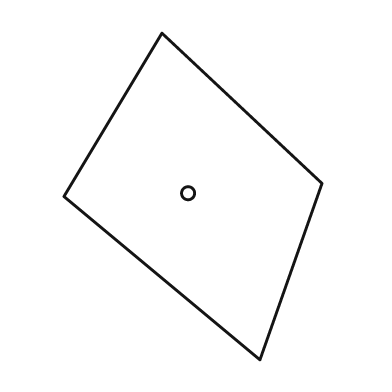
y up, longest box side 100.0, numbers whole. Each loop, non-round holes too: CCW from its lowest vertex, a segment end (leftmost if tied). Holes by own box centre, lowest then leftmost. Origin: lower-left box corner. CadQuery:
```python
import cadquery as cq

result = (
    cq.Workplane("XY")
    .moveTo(60.0, 0.0)
    .lineTo(79.0, 54.0)
    .lineTo(30.0, 100.0)
    .lineTo(0.0, 50.0)
    .close()
    .moveTo(38.0, 51.0)
    .circle(2.0)
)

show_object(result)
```